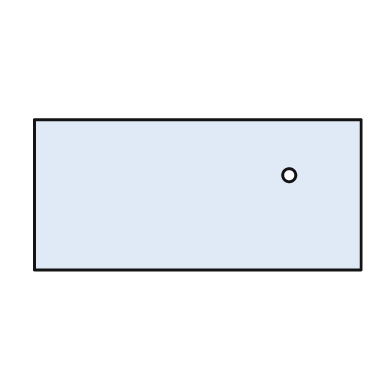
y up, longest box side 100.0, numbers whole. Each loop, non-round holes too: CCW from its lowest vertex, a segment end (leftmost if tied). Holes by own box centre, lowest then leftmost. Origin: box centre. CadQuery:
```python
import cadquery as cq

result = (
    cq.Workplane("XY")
    .moveTo(-50.0, -23.0)
    .lineTo(50.0, -23.0)
    .lineTo(50.0, 23.0)
    .lineTo(-50.0, 23.0)
    .close()
    .moveTo(28.0, 6.0)
    .circle(2.0)
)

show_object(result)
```